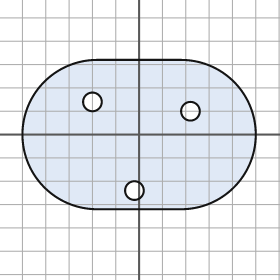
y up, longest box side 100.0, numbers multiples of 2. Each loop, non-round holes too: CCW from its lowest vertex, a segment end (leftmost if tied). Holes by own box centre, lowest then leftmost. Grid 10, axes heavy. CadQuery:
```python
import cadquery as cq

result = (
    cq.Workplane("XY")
    .moveTo(-18.0, -32.0)
    .lineTo(18.0, -32.0)
    .threePointArc((50.0, 0.0), (18.0, 32.0))
    .lineTo(-18.0, 32.0)
    .threePointArc((-50.0, 0.0), (-18.0, -32.0))
    .close()
    .moveTo(-2.0, -24.0)
    .circle(4.0)
    .moveTo(22.0, 10.0)
    .circle(4.0)
    .moveTo(-20.0, 14.0)
    .circle(4.0)
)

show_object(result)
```